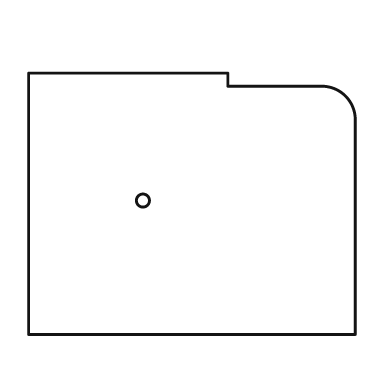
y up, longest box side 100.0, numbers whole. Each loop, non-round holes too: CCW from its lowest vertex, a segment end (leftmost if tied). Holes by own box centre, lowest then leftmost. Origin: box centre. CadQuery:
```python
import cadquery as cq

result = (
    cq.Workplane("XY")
    .moveTo(-50.0, -40.0)
    .lineTo(50.0, -40.0)
    .lineTo(50.0, 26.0)
    .threePointArc((47.0, 33.0), (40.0, 36.0))
    .lineTo(11.0, 36.0)
    .lineTo(11.0, 40.0)
    .lineTo(-50.0, 40.0)
    .close()
    .moveTo(-15.0, 1.0)
    .circle(2.0)
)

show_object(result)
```